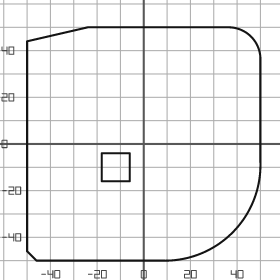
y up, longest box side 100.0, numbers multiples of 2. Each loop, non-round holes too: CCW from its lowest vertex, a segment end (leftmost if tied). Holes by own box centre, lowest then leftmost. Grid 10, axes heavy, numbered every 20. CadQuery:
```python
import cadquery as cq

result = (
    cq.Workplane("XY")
    .moveTo(-46.0, -50.0)
    .lineTo(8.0, -50.0)
    .threePointArc((38.0, -38.0), (50.0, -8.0))
    .lineTo(50.0, 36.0)
    .threePointArc((46.0, 46.0), (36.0, 50.0))
    .lineTo(-24.0, 50.0)
    .lineTo(-50.0, 44.0)
    .lineTo(-50.0, -46.0)
    .close()
    .moveTo(-18.0, -16.0)
    .lineTo(-6.0, -16.0)
    .lineTo(-6.0, -4.0)
    .lineTo(-18.0, -4.0)
    .close()
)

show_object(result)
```